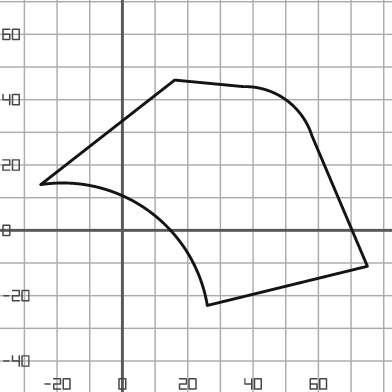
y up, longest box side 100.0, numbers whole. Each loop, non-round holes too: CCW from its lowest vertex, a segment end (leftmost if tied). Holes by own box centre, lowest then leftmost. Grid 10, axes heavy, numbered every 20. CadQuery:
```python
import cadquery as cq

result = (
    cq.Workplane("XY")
    .moveTo(26.0, -23.0)
    .lineTo(75.0, -11.0)
    .lineTo(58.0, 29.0)
    .threePointArc((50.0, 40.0), (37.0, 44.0))
    .lineTo(16.0, 46.0)
    .lineTo(-25.0, 14.0)
    .threePointArc((8.0, 6.0), (26.0, -23.0))
    .close()
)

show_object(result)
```